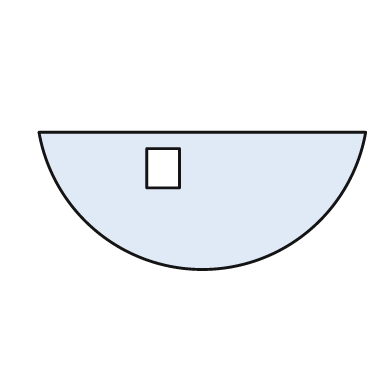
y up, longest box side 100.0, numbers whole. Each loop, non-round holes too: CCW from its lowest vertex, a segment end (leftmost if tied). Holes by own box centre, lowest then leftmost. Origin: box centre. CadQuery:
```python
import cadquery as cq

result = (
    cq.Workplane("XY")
    .moveTo(-50.0, 21.0)
    .threePointArc((0.0, -21.0), (50.0, 21.0))
    .close()
    .moveTo(-17.0, 4.0)
    .lineTo(-7.0, 4.0)
    .lineTo(-7.0, 16.0)
    .lineTo(-17.0, 16.0)
    .close()
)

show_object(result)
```